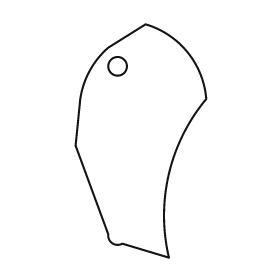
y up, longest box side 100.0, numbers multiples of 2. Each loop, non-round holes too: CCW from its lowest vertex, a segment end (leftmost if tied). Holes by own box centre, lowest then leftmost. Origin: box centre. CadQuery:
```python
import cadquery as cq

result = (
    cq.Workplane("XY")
    .moveTo(12.0, -50.0)
    .threePointArc((12.0, -14.0), (28.0, 18.0))
    .threePointArc((20.0, 38.0), (2.0, 50.0))
    .lineTo(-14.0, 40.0)
    .threePointArc((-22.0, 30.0), (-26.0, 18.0))
    .lineTo(-28.0, -2.0)
    .lineTo(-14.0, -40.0)
    .threePointArc((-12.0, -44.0), (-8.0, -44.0))
    .close()
    .moveTo(-10.0, 32.0)
    .circle(4.0)
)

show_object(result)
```